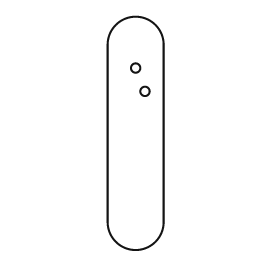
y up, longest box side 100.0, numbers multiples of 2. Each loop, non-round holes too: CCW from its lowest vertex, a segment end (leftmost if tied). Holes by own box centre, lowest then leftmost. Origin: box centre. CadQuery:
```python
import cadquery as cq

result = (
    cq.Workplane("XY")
    .moveTo(-12.0, -38.0)
    .threePointArc((0.0, -50.0), (12.0, -38.0))
    .lineTo(12.0, 38.0)
    .threePointArc((0.0, 50.0), (-12.0, 38.0))
    .close()
    .moveTo(4.0, 18.0)
    .circle(2.0)
    .moveTo(0.0, 28.0)
    .circle(2.0)
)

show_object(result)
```